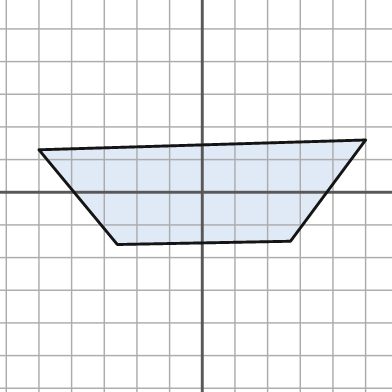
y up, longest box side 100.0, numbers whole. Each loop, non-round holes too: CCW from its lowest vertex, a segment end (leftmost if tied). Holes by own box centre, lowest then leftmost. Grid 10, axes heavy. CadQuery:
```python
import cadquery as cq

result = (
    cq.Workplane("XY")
    .moveTo(-26.0, -16.0)
    .lineTo(27.0, -15.0)
    .lineTo(50.0, 16.0)
    .lineTo(-50.0, 13.0)
    .close()
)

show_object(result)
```